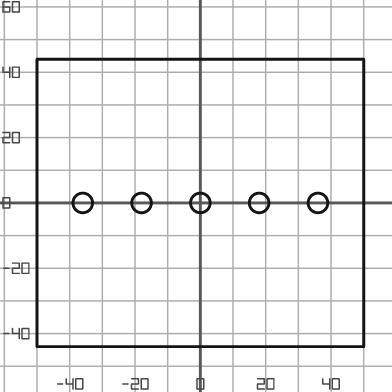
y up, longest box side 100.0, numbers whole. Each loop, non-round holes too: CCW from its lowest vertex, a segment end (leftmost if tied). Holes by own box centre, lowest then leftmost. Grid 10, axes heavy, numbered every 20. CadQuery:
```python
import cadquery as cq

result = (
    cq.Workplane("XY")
    .moveTo(-50.0, -44.0)
    .lineTo(50.0, -44.0)
    .lineTo(50.0, 44.0)
    .lineTo(-50.0, 44.0)
    .close()
    .moveTo(-36.0, 0.0)
    .circle(3.0)
    .moveTo(-18.0, 0.0)
    .circle(3.0)
    .moveTo(0.0, 0.0)
    .circle(3.0)
    .moveTo(18.0, 0.0)
    .circle(3.0)
    .moveTo(36.0, 0.0)
    .circle(3.0)
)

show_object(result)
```